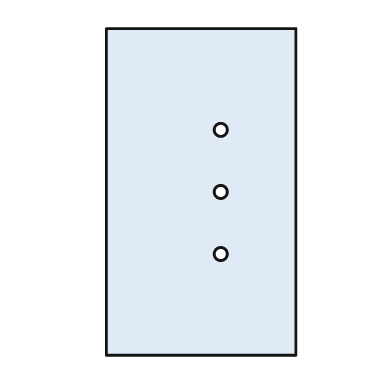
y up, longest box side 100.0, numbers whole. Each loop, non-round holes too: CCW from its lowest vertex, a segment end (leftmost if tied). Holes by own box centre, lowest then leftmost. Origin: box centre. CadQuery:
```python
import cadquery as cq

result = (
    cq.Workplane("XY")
    .moveTo(-29.0, -50.0)
    .lineTo(29.0, -50.0)
    .lineTo(29.0, 50.0)
    .lineTo(-29.0, 50.0)
    .close()
    .moveTo(6.0, -19.0)
    .circle(2.0)
    .moveTo(6.0, 0.0)
    .circle(2.0)
    .moveTo(6.0, 19.0)
    .circle(2.0)
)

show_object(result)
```